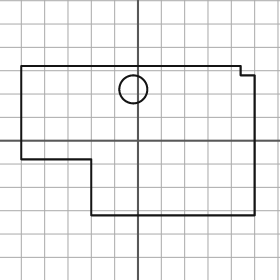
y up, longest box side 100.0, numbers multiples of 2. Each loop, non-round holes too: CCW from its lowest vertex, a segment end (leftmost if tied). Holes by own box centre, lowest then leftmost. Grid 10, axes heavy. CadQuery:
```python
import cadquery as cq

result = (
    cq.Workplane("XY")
    .moveTo(-20.0, -32.0)
    .lineTo(50.0, -32.0)
    .lineTo(50.0, 28.0)
    .lineTo(44.0, 28.0)
    .lineTo(44.0, 32.0)
    .lineTo(-50.0, 32.0)
    .lineTo(-50.0, -8.0)
    .lineTo(-20.0, -8.0)
    .close()
    .moveTo(-2.0, 22.0)
    .circle(6.0)
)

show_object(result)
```